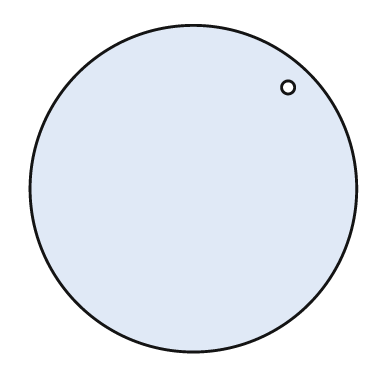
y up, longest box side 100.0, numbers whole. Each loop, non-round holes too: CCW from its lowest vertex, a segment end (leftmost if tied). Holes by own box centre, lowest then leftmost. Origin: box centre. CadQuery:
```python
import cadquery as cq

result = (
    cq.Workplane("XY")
    .moveTo(0.0, 0.0)
    .circle(50.0)
    .moveTo(29.0, 31.0)
    .circle(2.0)
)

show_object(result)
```